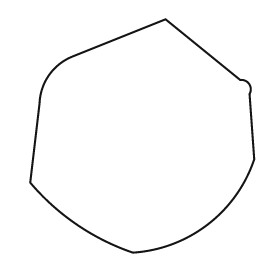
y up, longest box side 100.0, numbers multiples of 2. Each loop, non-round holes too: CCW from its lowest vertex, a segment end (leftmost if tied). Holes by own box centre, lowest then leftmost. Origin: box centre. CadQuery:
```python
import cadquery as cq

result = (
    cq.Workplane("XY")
    .moveTo(-4.0, -50.0)
    .threePointArc((28.0, -38.0), (48.0, -10.0))
    .lineTo(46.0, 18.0)
    .threePointArc((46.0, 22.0), (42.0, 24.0))
    .lineTo(10.0, 50.0)
    .lineTo(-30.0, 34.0)
    .threePointArc((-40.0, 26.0), (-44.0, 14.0))
    .lineTo(-48.0, -20.0)
    .threePointArc((-28.0, -38.0), (-4.0, -50.0))
    .close()
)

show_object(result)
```